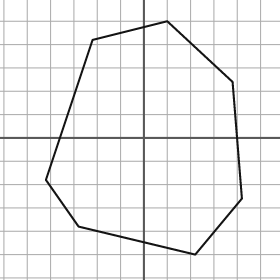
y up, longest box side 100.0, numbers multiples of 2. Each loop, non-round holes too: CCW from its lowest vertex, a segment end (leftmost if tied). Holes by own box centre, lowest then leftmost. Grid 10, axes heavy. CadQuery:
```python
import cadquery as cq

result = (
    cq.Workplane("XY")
    .moveTo(22.0, -50.0)
    .lineTo(42.0, -26.0)
    .lineTo(38.0, 24.0)
    .lineTo(10.0, 50.0)
    .lineTo(-22.0, 42.0)
    .lineTo(-42.0, -18.0)
    .lineTo(-28.0, -38.0)
    .close()
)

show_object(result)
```